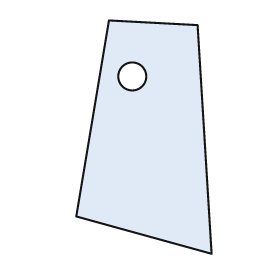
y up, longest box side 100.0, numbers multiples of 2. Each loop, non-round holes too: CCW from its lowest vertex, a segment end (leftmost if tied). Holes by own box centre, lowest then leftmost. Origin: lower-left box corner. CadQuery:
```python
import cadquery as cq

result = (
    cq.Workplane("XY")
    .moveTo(58.0, 0.0)
    .lineTo(52.0, 98.0)
    .lineTo(14.0, 100.0)
    .lineTo(0.0, 16.0)
    .close()
    .moveTo(24.0, 76.0)
    .circle(6.0)
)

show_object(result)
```